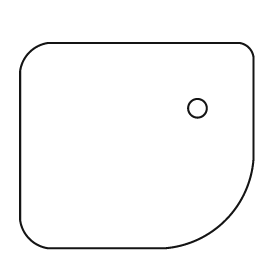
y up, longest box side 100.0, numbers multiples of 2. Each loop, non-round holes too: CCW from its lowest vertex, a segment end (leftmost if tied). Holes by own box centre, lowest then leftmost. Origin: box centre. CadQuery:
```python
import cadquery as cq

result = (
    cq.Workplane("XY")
    .moveTo(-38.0, -44.0)
    .lineTo(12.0, -44.0)
    .threePointArc((38.0, -32.0), (50.0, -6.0))
    .lineTo(50.0, 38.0)
    .threePointArc((48.0, 42.0), (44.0, 44.0))
    .lineTo(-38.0, 44.0)
    .threePointArc((-46.0, 40.0), (-50.0, 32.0))
    .lineTo(-50.0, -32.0)
    .threePointArc((-46.0, -40.0), (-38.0, -44.0))
    .close()
    .moveTo(26.0, 16.0)
    .circle(4.0)
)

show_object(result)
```